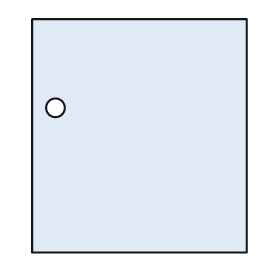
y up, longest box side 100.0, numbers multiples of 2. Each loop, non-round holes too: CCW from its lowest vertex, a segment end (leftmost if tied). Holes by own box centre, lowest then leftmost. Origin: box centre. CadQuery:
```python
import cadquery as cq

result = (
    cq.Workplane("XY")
    .moveTo(-46.0, -50.0)
    .lineTo(46.0, -50.0)
    .lineTo(46.0, 50.0)
    .lineTo(-46.0, 50.0)
    .close()
    .moveTo(-36.0, 12.0)
    .circle(4.0)
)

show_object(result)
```